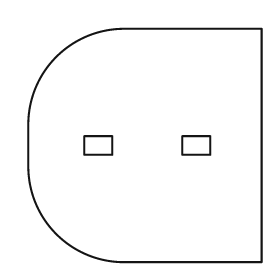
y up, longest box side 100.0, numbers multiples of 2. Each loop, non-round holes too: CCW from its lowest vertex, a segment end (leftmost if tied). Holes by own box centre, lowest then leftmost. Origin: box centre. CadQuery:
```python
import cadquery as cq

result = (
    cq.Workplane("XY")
    .moveTo(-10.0, -50.0)
    .lineTo(50.0, -50.0)
    .lineTo(50.0, 50.0)
    .lineTo(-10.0, 50.0)
    .threePointArc((-38.0, 38.0), (-50.0, 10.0))
    .lineTo(-50.0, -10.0)
    .threePointArc((-38.0, -38.0), (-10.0, -50.0))
    .close()
    .moveTo(-26.0, -4.0)
    .lineTo(-14.0, -4.0)
    .lineTo(-14.0, 4.0)
    .lineTo(-26.0, 4.0)
    .close()
    .moveTo(16.0, -4.0)
    .lineTo(28.0, -4.0)
    .lineTo(28.0, 4.0)
    .lineTo(16.0, 4.0)
    .close()
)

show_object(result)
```